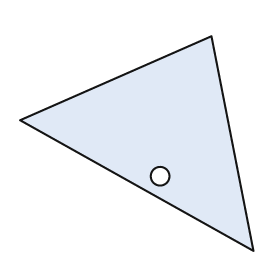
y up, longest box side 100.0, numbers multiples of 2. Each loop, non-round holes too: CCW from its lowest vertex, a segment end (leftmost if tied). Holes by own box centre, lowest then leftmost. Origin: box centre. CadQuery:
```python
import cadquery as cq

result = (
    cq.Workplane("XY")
    .moveTo(50.0, -46.0)
    .lineTo(32.0, 46.0)
    .lineTo(-50.0, 10.0)
    .close()
    .moveTo(10.0, -14.0)
    .circle(4.0)
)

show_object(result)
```